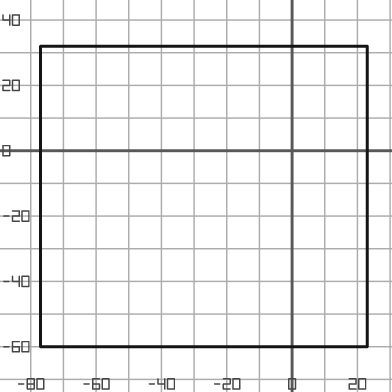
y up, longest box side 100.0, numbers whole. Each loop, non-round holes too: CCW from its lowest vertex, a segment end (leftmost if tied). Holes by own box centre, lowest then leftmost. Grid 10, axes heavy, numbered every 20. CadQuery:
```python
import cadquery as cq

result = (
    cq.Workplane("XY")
    .moveTo(-77.0, -60.0)
    .lineTo(23.0, -60.0)
    .lineTo(23.0, 32.0)
    .lineTo(-77.0, 32.0)
    .close()
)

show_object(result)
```